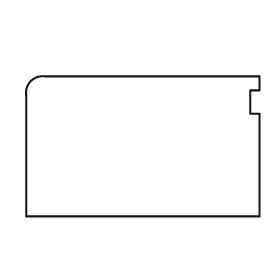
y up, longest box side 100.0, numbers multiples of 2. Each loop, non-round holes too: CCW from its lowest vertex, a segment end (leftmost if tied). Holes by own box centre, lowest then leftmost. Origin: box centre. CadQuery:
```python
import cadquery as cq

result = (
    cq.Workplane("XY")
    .moveTo(-50.0, -30.0)
    .lineTo(50.0, -30.0)
    .lineTo(50.0, 14.0)
    .lineTo(46.0, 14.0)
    .lineTo(46.0, 24.0)
    .lineTo(50.0, 24.0)
    .lineTo(50.0, 30.0)
    .lineTo(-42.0, 30.0)
    .threePointArc((-48.0, 28.0), (-50.0, 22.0))
    .close()
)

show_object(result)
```